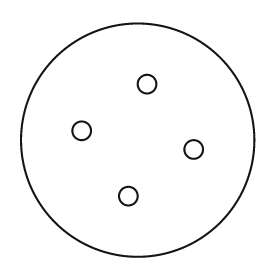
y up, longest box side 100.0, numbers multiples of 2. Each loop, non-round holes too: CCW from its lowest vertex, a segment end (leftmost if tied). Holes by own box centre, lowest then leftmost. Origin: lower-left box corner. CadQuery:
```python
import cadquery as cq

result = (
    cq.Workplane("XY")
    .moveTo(50.0, 50.0)
    .circle(50.0)
    .moveTo(46.0, 26.0)
    .circle(4.0)
    .moveTo(74.0, 46.0)
    .circle(4.0)
    .moveTo(26.0, 54.0)
    .circle(4.0)
    .moveTo(54.0, 74.0)
    .circle(4.0)
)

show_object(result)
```